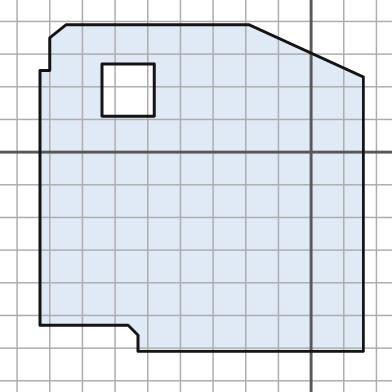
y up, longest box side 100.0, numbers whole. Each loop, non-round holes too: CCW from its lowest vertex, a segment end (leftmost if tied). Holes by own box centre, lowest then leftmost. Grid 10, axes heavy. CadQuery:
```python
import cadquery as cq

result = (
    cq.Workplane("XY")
    .moveTo(-53.0, -61.0)
    .lineTo(16.0, -61.0)
    .lineTo(16.0, 23.0)
    .lineTo(-19.0, 39.0)
    .lineTo(-75.0, 39.0)
    .lineTo(-80.0, 35.0)
    .lineTo(-80.0, 25.0)
    .lineTo(-83.0, 25.0)
    .lineTo(-83.0, -53.0)
    .lineTo(-56.0, -53.0)
    .lineTo(-53.0, -56.0)
    .close()
    .moveTo(-64.0, 11.0)
    .lineTo(-48.0, 11.0)
    .lineTo(-48.0, 27.0)
    .lineTo(-64.0, 27.0)
    .close()
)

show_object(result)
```